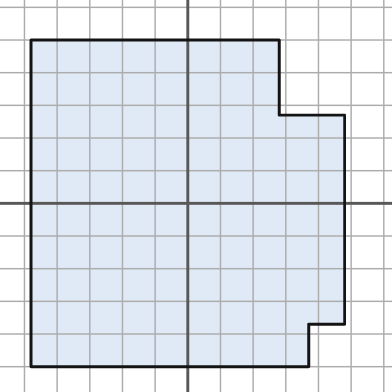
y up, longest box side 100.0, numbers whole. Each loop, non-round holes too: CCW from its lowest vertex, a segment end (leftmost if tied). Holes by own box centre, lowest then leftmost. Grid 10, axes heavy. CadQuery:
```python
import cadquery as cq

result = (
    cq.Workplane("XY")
    .moveTo(-48.0, -50.0)
    .lineTo(37.0, -50.0)
    .lineTo(37.0, -37.0)
    .lineTo(48.0, -37.0)
    .lineTo(48.0, 27.0)
    .lineTo(28.0, 27.0)
    .lineTo(28.0, 50.0)
    .lineTo(-48.0, 50.0)
    .close()
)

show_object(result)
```